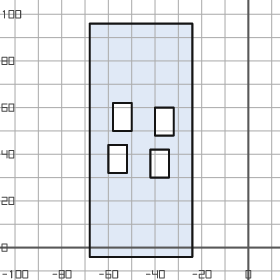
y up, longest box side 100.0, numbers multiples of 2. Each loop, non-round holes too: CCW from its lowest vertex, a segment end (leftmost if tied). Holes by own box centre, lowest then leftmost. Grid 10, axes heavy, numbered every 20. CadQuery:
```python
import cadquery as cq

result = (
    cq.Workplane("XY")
    .moveTo(-68.0, -4.0)
    .lineTo(-24.0, -4.0)
    .lineTo(-24.0, 96.0)
    .lineTo(-68.0, 96.0)
    .close()
    .moveTo(-42.0, 30.0)
    .lineTo(-34.0, 30.0)
    .lineTo(-34.0, 42.0)
    .lineTo(-42.0, 42.0)
    .close()
    .moveTo(-60.0, 32.0)
    .lineTo(-52.0, 32.0)
    .lineTo(-52.0, 44.0)
    .lineTo(-60.0, 44.0)
    .close()
    .moveTo(-40.0, 48.0)
    .lineTo(-32.0, 48.0)
    .lineTo(-32.0, 60.0)
    .lineTo(-40.0, 60.0)
    .close()
    .moveTo(-58.0, 50.0)
    .lineTo(-50.0, 50.0)
    .lineTo(-50.0, 62.0)
    .lineTo(-58.0, 62.0)
    .close()
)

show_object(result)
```